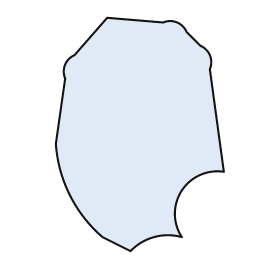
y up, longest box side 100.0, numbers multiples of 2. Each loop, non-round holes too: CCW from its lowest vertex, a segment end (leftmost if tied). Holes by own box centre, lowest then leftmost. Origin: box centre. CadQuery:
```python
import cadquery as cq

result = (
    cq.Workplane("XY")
    .moveTo(-4.0, -50.0)
    .threePointArc((6.0, -44.0), (18.0, -44.0))
    .threePointArc((18.0, -24.0), (36.0, -16.0))
    .lineTo(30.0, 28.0)
    .threePointArc((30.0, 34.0), (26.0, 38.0))
    .lineTo(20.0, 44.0)
    .threePointArc((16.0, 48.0), (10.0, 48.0))
    .lineTo(-14.0, 50.0)
    .lineTo(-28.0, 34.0)
    .threePointArc((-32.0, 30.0), (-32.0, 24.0))
    .lineTo(-36.0, -4.0)
    .threePointArc((-30.0, -26.0), (-16.0, -44.0))
    .close()
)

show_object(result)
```